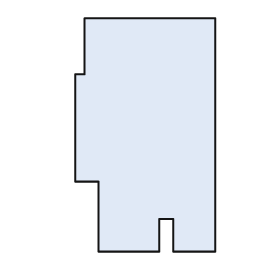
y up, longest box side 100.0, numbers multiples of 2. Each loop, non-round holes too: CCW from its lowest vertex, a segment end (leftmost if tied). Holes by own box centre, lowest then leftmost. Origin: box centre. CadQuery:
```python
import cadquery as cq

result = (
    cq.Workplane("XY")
    .moveTo(-20.0, -50.0)
    .lineTo(6.0, -50.0)
    .lineTo(6.0, -36.0)
    .lineTo(12.0, -36.0)
    .lineTo(12.0, -50.0)
    .lineTo(30.0, -50.0)
    .lineTo(30.0, 50.0)
    .lineTo(-26.0, 50.0)
    .lineTo(-26.0, 26.0)
    .lineTo(-30.0, 26.0)
    .lineTo(-30.0, -20.0)
    .lineTo(-20.0, -20.0)
    .close()
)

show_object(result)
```